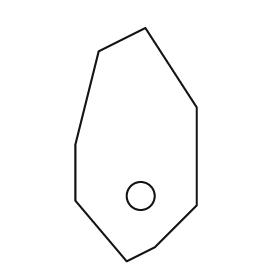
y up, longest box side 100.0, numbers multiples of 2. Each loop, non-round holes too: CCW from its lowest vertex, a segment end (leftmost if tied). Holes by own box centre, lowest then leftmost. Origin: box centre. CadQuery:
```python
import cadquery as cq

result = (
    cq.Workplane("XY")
    .moveTo(-4.0, -50.0)
    .lineTo(8.0, -44.0)
    .lineTo(26.0, -26.0)
    .lineTo(26.0, 16.0)
    .lineTo(4.0, 50.0)
    .lineTo(-16.0, 40.0)
    .lineTo(-26.0, 0.0)
    .lineTo(-26.0, -24.0)
    .close()
    .moveTo(2.0, -22.0)
    .circle(6.0)
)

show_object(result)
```